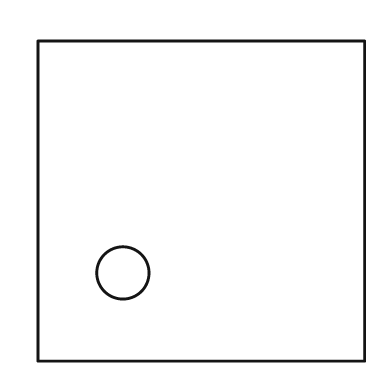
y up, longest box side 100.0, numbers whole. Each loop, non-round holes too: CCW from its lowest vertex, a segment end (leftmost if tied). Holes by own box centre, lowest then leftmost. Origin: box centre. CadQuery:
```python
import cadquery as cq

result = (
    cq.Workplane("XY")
    .moveTo(-50.0, -49.0)
    .lineTo(50.0, -49.0)
    .lineTo(50.0, 49.0)
    .lineTo(-50.0, 49.0)
    .close()
    .moveTo(-24.0, -22.0)
    .circle(8.0)
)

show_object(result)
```